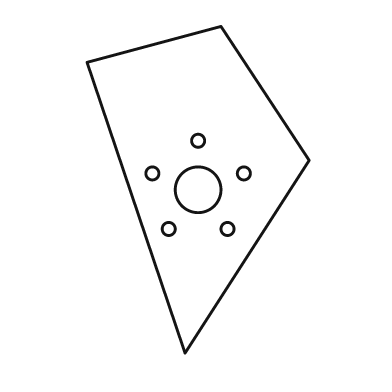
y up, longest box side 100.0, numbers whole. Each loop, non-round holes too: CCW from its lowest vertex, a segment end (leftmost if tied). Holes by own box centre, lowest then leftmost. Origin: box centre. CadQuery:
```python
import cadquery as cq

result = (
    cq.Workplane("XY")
    .moveTo(-4.0, -50.0)
    .lineTo(34.0, 9.0)
    .lineTo(7.0, 50.0)
    .lineTo(-34.0, 39.0)
    .close()
    .moveTo(-9.0, -12.0)
    .circle(2.0)
    .moveTo(9.0, -12.0)
    .circle(2.0)
    .moveTo(0.0, 0.0)
    .circle(7.0)
    .moveTo(-14.0, 5.0)
    .circle(2.0)
    .moveTo(14.0, 5.0)
    .circle(2.0)
    .moveTo(0.0, 15.0)
    .circle(2.0)
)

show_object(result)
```